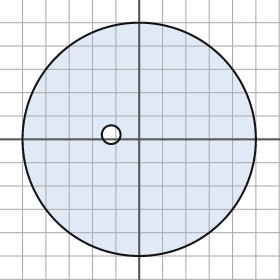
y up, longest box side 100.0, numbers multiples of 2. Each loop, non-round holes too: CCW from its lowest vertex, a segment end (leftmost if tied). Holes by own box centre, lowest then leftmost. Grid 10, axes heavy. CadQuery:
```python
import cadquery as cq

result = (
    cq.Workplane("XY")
    .moveTo(0.0, 0.0)
    .circle(50.0)
    .moveTo(-12.0, 2.0)
    .circle(4.0)
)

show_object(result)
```